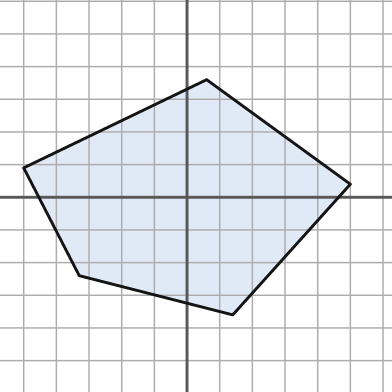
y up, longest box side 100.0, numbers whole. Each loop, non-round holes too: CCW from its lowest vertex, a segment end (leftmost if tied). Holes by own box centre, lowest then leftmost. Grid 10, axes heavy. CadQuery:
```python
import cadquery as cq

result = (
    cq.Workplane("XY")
    .moveTo(14.0, -36.0)
    .lineTo(50.0, 4.0)
    .lineTo(6.0, 36.0)
    .lineTo(-50.0, 9.0)
    .lineTo(-33.0, -24.0)
    .close()
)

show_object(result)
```